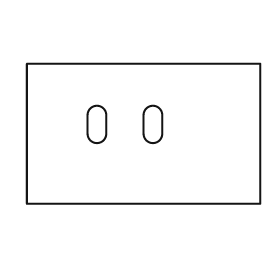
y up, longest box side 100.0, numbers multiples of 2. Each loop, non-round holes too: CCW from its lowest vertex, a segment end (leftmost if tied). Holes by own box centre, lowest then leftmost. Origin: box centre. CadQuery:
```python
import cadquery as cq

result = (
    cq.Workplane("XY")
    .moveTo(-50.0, -30.0)
    .lineTo(50.0, -30.0)
    .lineTo(50.0, 30.0)
    .lineTo(-50.0, 30.0)
    .close()
    .moveTo(-24.0, 0.0)
    .threePointArc((-20.0, -4.0), (-16.0, 0.0))
    .lineTo(-16.0, 8.0)
    .threePointArc((-20.0, 12.0), (-24.0, 8.0))
    .close()
    .moveTo(0.0, 0.0)
    .threePointArc((4.0, -4.0), (8.0, 0.0))
    .lineTo(8.0, 8.0)
    .threePointArc((4.0, 12.0), (0.0, 8.0))
    .close()
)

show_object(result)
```